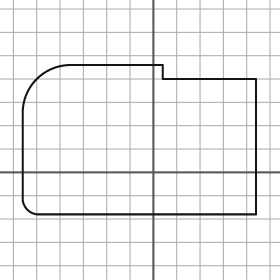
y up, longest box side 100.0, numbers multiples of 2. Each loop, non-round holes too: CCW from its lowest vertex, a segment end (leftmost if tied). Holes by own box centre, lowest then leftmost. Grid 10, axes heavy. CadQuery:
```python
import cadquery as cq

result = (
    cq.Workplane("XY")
    .moveTo(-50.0, -18.0)
    .lineTo(44.0, -18.0)
    .lineTo(44.0, 40.0)
    .lineTo(4.0, 40.0)
    .lineTo(4.0, 46.0)
    .lineTo(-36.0, 46.0)
    .threePointArc((-50.0, 40.0), (-56.0, 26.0))
    .lineTo(-56.0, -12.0)
    .threePointArc((-54.0, -16.0), (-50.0, -18.0))
    .close()
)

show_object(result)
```